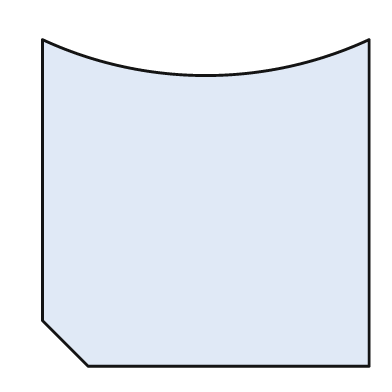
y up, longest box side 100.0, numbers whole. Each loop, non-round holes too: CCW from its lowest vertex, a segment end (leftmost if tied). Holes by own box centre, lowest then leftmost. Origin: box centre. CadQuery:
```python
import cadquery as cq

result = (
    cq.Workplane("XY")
    .moveTo(-36.0, -50.0)
    .lineTo(50.0, -50.0)
    .lineTo(50.0, 50.0)
    .threePointArc((0.0, 39.0), (-50.0, 50.0))
    .lineTo(-50.0, -36.0)
    .close()
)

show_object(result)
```